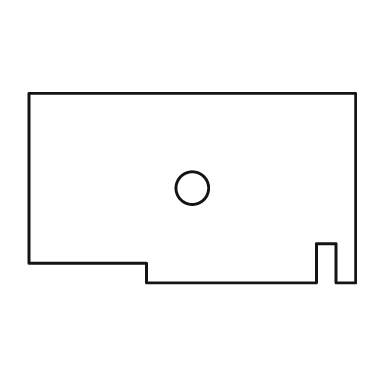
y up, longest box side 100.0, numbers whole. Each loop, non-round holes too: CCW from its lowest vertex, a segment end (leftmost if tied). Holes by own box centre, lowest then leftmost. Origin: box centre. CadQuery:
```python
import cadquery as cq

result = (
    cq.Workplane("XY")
    .moveTo(-14.0, -29.0)
    .lineTo(38.0, -29.0)
    .lineTo(38.0, -17.0)
    .lineTo(44.0, -17.0)
    .lineTo(44.0, -29.0)
    .lineTo(50.0, -29.0)
    .lineTo(50.0, 29.0)
    .lineTo(-50.0, 29.0)
    .lineTo(-50.0, -23.0)
    .lineTo(-14.0, -23.0)
    .close()
    .moveTo(0.0, 0.0)
    .circle(5.0)
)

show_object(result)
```